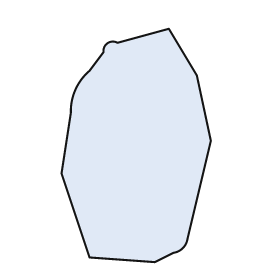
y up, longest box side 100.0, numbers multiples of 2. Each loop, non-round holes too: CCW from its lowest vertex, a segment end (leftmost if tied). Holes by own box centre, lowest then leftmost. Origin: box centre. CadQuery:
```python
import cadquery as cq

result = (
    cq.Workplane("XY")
    .moveTo(8.0, -50.0)
    .lineTo(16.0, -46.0)
    .threePointArc((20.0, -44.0), (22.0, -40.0))
    .lineTo(32.0, 2.0)
    .lineTo(26.0, 30.0)
    .lineTo(14.0, 50.0)
    .lineTo(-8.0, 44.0)
    .threePointArc((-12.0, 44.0), (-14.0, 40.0))
    .lineTo(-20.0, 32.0)
    .threePointArc((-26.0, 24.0), (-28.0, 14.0))
    .lineTo(-32.0, -12.0)
    .lineTo(-20.0, -48.0)
    .close()
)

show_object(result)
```